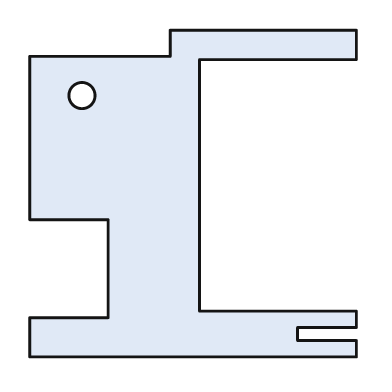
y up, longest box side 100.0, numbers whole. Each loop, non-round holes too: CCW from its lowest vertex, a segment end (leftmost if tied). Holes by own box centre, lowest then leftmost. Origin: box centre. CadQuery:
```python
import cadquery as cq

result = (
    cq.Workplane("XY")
    .moveTo(-50.0, -50.0)
    .lineTo(50.0, -50.0)
    .lineTo(50.0, -45.0)
    .lineTo(32.0, -45.0)
    .lineTo(32.0, -41.0)
    .lineTo(50.0, -41.0)
    .lineTo(50.0, -36.0)
    .lineTo(2.0, -36.0)
    .lineTo(2.0, 41.0)
    .lineTo(50.0, 41.0)
    .lineTo(50.0, 50.0)
    .lineTo(-7.0, 50.0)
    .lineTo(-7.0, 42.0)
    .lineTo(-50.0, 42.0)
    .lineTo(-50.0, -8.0)
    .lineTo(-26.0, -8.0)
    .lineTo(-26.0, -38.0)
    .lineTo(-50.0, -38.0)
    .close()
    .moveTo(-34.0, 30.0)
    .circle(4.0)
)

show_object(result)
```